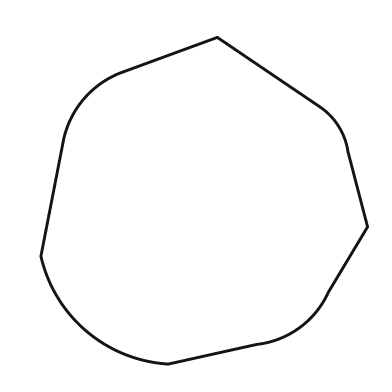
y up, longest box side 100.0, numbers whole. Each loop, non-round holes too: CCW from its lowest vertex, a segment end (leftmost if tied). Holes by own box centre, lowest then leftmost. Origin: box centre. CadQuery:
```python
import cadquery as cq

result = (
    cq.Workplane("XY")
    .moveTo(-11.0, -50.0)
    .lineTo(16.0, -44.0)
    .threePointArc((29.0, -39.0), (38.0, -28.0))
    .lineTo(50.0, -8.0)
    .lineTo(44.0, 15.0)
    .threePointArc((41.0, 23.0), (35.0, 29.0))
    .lineTo(4.0, 50.0)
    .lineTo(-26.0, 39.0)
    .threePointArc((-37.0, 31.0), (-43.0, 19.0))
    .lineTo(-50.0, -17.0)
    .threePointArc((-36.0, -40.0), (-11.0, -50.0))
    .close()
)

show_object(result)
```